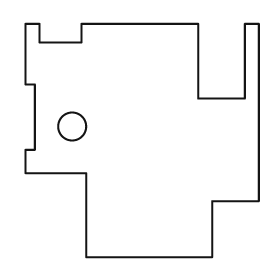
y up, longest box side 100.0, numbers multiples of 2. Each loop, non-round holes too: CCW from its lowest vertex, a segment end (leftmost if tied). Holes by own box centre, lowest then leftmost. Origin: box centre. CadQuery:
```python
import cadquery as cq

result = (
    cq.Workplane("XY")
    .moveTo(-24.0, -50.0)
    .lineTo(30.0, -50.0)
    .lineTo(30.0, -26.0)
    .lineTo(50.0, -26.0)
    .lineTo(50.0, 50.0)
    .lineTo(44.0, 50.0)
    .lineTo(44.0, 18.0)
    .lineTo(24.0, 18.0)
    .lineTo(24.0, 50.0)
    .lineTo(-26.0, 50.0)
    .lineTo(-26.0, 42.0)
    .lineTo(-44.0, 42.0)
    .lineTo(-44.0, 50.0)
    .lineTo(-50.0, 50.0)
    .lineTo(-50.0, 24.0)
    .lineTo(-46.0, 24.0)
    .lineTo(-46.0, -4.0)
    .lineTo(-50.0, -4.0)
    .lineTo(-50.0, -14.0)
    .lineTo(-24.0, -14.0)
    .close()
    .moveTo(-30.0, 6.0)
    .circle(6.0)
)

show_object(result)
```